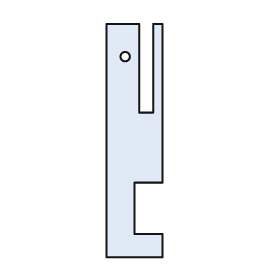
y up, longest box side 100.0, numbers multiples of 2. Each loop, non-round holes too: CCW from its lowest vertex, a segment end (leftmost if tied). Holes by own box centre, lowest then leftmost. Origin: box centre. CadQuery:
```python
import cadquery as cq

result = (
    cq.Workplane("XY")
    .moveTo(-12.0, -50.0)
    .lineTo(12.0, -50.0)
    .lineTo(12.0, -40.0)
    .lineTo(0.0, -40.0)
    .lineTo(0.0, -18.0)
    .lineTo(12.0, -18.0)
    .lineTo(12.0, 50.0)
    .lineTo(8.0, 50.0)
    .lineTo(8.0, 12.0)
    .lineTo(2.0, 12.0)
    .lineTo(2.0, 50.0)
    .lineTo(-12.0, 50.0)
    .close()
    .moveTo(-4.0, 36.0)
    .circle(2.0)
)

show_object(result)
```